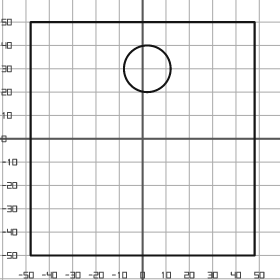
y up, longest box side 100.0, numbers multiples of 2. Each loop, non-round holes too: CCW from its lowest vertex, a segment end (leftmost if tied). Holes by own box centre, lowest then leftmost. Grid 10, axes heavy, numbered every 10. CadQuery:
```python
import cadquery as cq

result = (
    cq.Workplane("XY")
    .moveTo(-48.0, -50.0)
    .lineTo(48.0, -50.0)
    .lineTo(48.0, 50.0)
    .lineTo(-48.0, 50.0)
    .close()
    .moveTo(2.0, 30.0)
    .circle(10.0)
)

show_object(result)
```